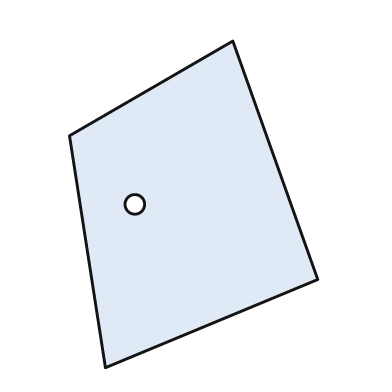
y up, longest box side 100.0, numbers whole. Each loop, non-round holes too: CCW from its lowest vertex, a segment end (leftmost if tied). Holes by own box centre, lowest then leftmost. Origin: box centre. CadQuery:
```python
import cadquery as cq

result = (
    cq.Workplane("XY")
    .moveTo(-27.0, -50.0)
    .lineTo(38.0, -23.0)
    .lineTo(12.0, 50.0)
    .lineTo(-38.0, 21.0)
    .close()
    .moveTo(-18.0, 0.0)
    .circle(3.0)
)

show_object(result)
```